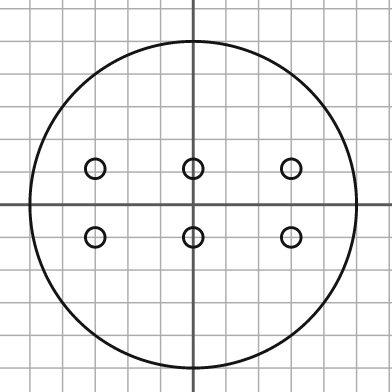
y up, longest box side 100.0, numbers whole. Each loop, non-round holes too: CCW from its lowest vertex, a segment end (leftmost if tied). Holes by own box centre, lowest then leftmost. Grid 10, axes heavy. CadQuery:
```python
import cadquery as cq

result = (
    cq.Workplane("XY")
    .moveTo(0.0, 0.0)
    .circle(50.0)
    .moveTo(-30.0, -10.0)
    .circle(3.0)
    .moveTo(0.0, -10.0)
    .circle(3.0)
    .moveTo(30.0, -10.0)
    .circle(3.0)
    .moveTo(-30.0, 11.0)
    .circle(3.0)
    .moveTo(0.0, 11.0)
    .circle(3.0)
    .moveTo(30.0, 11.0)
    .circle(3.0)
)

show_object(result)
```